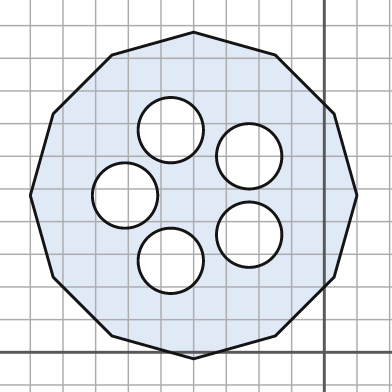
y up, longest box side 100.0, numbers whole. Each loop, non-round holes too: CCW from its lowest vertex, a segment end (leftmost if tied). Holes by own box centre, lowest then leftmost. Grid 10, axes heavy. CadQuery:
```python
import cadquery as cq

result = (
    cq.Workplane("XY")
    .moveTo(-40.0, -2.0)
    .lineTo(-15.0, 5.0)
    .lineTo(3.0, 23.0)
    .lineTo(10.0, 48.0)
    .lineTo(3.0, 73.0)
    .lineTo(-15.0, 91.0)
    .lineTo(-40.0, 98.0)
    .lineTo(-65.0, 91.0)
    .lineTo(-83.0, 73.0)
    .lineTo(-90.0, 48.0)
    .lineTo(-83.0, 23.0)
    .lineTo(-65.0, 5.0)
    .close()
    .moveTo(-47.0, 28.0)
    .circle(10.0)
    .moveTo(-23.0, 36.0)
    .circle(10.0)
    .moveTo(-61.0, 48.0)
    .circle(10.0)
    .moveTo(-23.0, 60.0)
    .circle(10.0)
    .moveTo(-47.0, 68.0)
    .circle(10.0)
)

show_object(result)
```